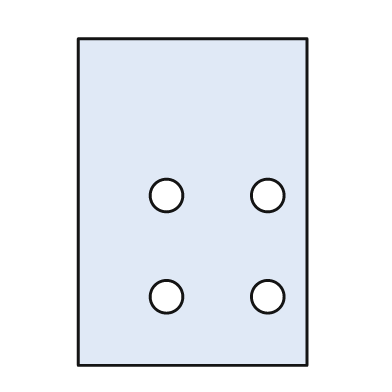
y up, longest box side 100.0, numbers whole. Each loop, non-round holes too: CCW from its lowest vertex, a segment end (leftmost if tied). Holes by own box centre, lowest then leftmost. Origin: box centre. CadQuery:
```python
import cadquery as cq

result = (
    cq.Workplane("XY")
    .moveTo(-35.0, -50.0)
    .lineTo(35.0, -50.0)
    .lineTo(35.0, 50.0)
    .lineTo(-35.0, 50.0)
    .close()
    .moveTo(-8.0, -29.0)
    .circle(5.0)
    .moveTo(23.0, -29.0)
    .circle(5.0)
    .moveTo(-8.0, 2.0)
    .circle(5.0)
    .moveTo(23.0, 2.0)
    .circle(5.0)
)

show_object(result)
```